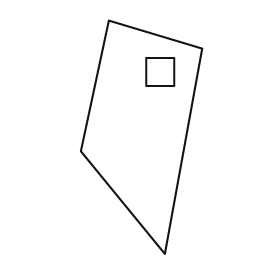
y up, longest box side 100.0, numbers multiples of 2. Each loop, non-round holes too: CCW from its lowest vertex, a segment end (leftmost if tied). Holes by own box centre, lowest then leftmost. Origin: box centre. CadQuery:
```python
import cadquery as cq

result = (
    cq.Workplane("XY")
    .moveTo(10.0, -50.0)
    .lineTo(26.0, 38.0)
    .lineTo(-14.0, 50.0)
    .lineTo(-26.0, -6.0)
    .close()
    .moveTo(2.0, 22.0)
    .lineTo(14.0, 22.0)
    .lineTo(14.0, 34.0)
    .lineTo(2.0, 34.0)
    .close()
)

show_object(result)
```